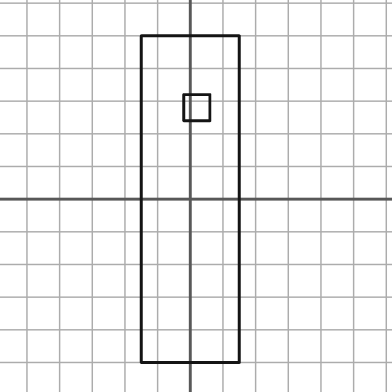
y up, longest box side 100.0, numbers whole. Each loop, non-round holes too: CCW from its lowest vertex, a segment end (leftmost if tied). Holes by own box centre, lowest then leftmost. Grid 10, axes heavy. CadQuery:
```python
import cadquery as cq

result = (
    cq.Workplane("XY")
    .moveTo(-15.0, -50.0)
    .lineTo(15.0, -50.0)
    .lineTo(15.0, 50.0)
    .lineTo(-15.0, 50.0)
    .close()
    .moveTo(-2.0, 24.0)
    .lineTo(6.0, 24.0)
    .lineTo(6.0, 32.0)
    .lineTo(-2.0, 32.0)
    .close()
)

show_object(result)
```